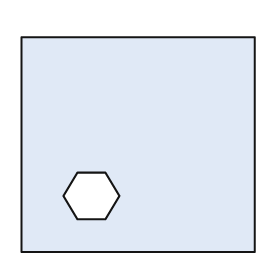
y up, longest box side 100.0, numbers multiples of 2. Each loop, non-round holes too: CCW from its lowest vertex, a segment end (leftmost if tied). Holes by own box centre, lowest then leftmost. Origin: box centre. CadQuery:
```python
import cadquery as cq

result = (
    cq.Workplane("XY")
    .moveTo(-50.0, -46.0)
    .lineTo(50.0, -46.0)
    .lineTo(50.0, 46.0)
    .lineTo(-50.0, 46.0)
    .close()
    .moveTo(-26.0, -32.0)
    .lineTo(-14.0, -32.0)
    .lineTo(-8.0, -22.0)
    .lineTo(-14.0, -12.0)
    .lineTo(-26.0, -12.0)
    .lineTo(-32.0, -22.0)
    .close()
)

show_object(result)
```